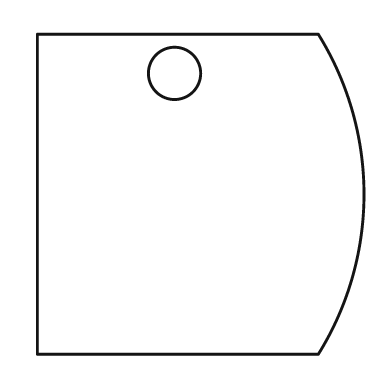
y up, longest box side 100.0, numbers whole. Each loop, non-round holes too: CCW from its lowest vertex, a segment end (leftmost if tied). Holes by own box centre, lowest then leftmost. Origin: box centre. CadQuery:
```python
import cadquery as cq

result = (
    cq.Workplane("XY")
    .moveTo(-50.0, -49.0)
    .lineTo(36.0, -49.0)
    .threePointArc((50.0, 0.0), (36.0, 49.0))
    .lineTo(-50.0, 49.0)
    .close()
    .moveTo(-8.0, 37.0)
    .circle(8.0)
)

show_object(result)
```